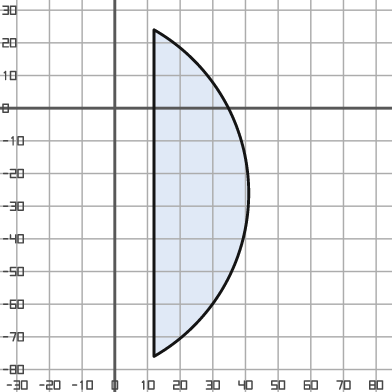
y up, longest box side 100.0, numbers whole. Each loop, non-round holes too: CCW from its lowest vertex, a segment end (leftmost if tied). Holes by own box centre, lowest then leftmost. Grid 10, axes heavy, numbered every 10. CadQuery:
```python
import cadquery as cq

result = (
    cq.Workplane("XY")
    .moveTo(12.0, -76.0)
    .threePointArc((41.0, -26.0), (12.0, 24.0))
    .close()
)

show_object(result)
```